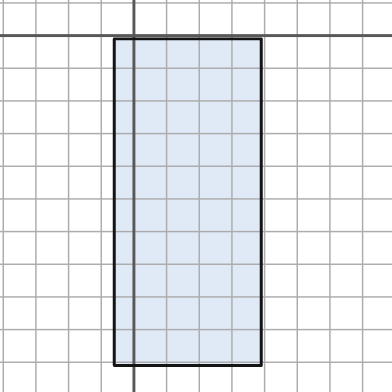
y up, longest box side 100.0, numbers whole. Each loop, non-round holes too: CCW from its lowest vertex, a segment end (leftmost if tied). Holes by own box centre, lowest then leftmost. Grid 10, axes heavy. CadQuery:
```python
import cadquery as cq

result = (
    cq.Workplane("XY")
    .moveTo(-6.0, -101.0)
    .lineTo(39.0, -101.0)
    .lineTo(39.0, -1.0)
    .lineTo(-6.0, -1.0)
    .close()
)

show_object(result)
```